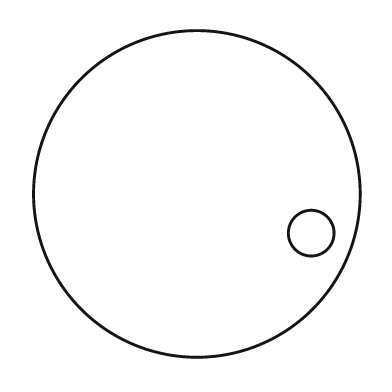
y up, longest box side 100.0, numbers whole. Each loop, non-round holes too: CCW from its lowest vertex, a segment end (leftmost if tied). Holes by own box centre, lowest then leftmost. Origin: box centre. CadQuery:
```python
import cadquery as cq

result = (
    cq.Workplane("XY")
    .moveTo(0.0, 0.0)
    .circle(50.0)
    .moveTo(35.0, -12.0)
    .circle(7.0)
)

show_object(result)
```